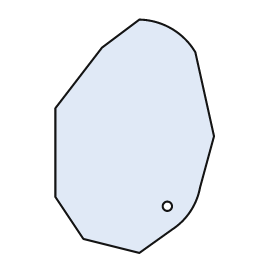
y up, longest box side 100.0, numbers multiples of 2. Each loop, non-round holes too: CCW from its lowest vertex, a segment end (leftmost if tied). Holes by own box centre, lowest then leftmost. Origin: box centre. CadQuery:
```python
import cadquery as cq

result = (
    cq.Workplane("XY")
    .moveTo(2.0, -50.0)
    .lineTo(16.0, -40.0)
    .threePointArc((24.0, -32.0), (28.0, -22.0))
    .lineTo(34.0, 0.0)
    .lineTo(26.0, 36.0)
    .threePointArc((16.0, 46.0), (2.0, 50.0))
    .lineTo(-14.0, 38.0)
    .lineTo(-34.0, 12.0)
    .lineTo(-34.0, -26.0)
    .lineTo(-22.0, -44.0)
    .close()
    .moveTo(14.0, -30.0)
    .circle(2.0)
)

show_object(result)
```